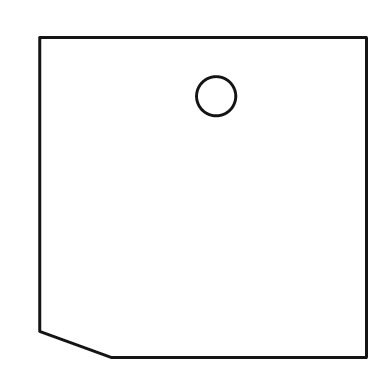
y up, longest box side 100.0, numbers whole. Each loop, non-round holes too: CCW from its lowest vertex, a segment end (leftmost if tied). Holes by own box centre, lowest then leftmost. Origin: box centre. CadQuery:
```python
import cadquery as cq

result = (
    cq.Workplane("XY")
    .moveTo(-28.0, -49.0)
    .lineTo(50.0, -49.0)
    .lineTo(50.0, 49.0)
    .lineTo(-50.0, 49.0)
    .lineTo(-50.0, -41.0)
    .close()
    .moveTo(4.0, 31.0)
    .circle(6.0)
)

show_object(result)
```